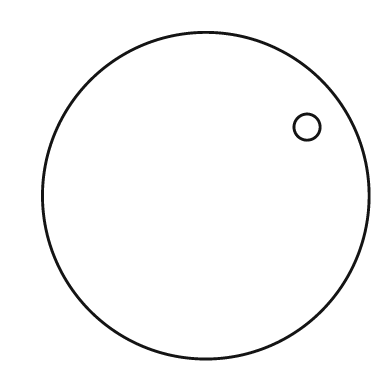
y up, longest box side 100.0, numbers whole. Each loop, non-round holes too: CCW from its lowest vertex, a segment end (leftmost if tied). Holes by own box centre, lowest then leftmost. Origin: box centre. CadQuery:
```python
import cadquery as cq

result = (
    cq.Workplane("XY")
    .moveTo(0.0, 0.0)
    .circle(50.0)
    .moveTo(31.0, 21.0)
    .circle(4.0)
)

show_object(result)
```